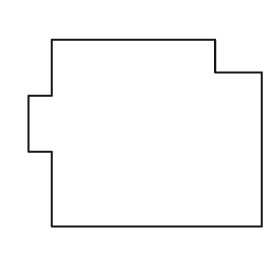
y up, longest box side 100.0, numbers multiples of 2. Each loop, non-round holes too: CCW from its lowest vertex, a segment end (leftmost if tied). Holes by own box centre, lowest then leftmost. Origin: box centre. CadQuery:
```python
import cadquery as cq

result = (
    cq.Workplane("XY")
    .moveTo(-40.0, -40.0)
    .lineTo(50.0, -40.0)
    .lineTo(50.0, 26.0)
    .lineTo(30.0, 26.0)
    .lineTo(30.0, 40.0)
    .lineTo(-40.0, 40.0)
    .lineTo(-40.0, 16.0)
    .lineTo(-50.0, 16.0)
    .lineTo(-50.0, -8.0)
    .lineTo(-40.0, -8.0)
    .close()
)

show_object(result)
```